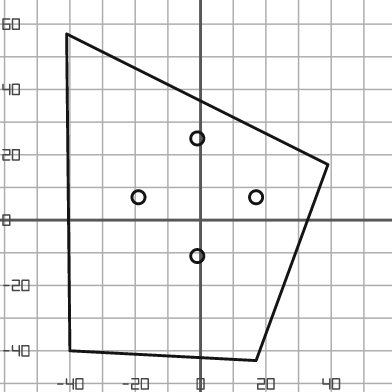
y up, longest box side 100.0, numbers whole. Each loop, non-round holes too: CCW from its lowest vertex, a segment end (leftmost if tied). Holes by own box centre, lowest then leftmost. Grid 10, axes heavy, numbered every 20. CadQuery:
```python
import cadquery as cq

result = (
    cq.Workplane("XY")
    .moveTo(17.0, -43.0)
    .lineTo(39.0, 17.0)
    .lineTo(-41.0, 57.0)
    .lineTo(-40.0, -40.0)
    .close()
    .moveTo(-1.0, -11.0)
    .circle(2.0)
    .moveTo(-19.0, 7.0)
    .circle(2.0)
    .moveTo(17.0, 7.0)
    .circle(2.0)
    .moveTo(-1.0, 25.0)
    .circle(2.0)
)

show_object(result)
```